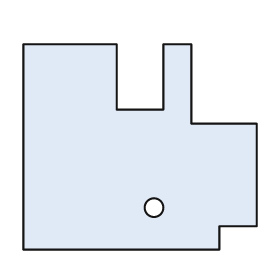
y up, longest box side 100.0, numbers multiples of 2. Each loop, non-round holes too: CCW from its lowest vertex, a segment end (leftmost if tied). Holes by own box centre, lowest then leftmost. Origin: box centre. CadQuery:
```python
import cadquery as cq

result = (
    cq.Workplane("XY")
    .moveTo(-50.0, -44.0)
    .lineTo(34.0, -44.0)
    .lineTo(34.0, -34.0)
    .lineTo(50.0, -34.0)
    .lineTo(50.0, 10.0)
    .lineTo(22.0, 10.0)
    .lineTo(22.0, 44.0)
    .lineTo(10.0, 44.0)
    .lineTo(10.0, 16.0)
    .lineTo(-10.0, 16.0)
    .lineTo(-10.0, 44.0)
    .lineTo(-50.0, 44.0)
    .close()
    .moveTo(6.0, -26.0)
    .circle(4.0)
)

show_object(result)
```